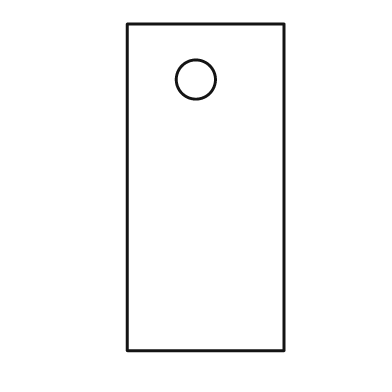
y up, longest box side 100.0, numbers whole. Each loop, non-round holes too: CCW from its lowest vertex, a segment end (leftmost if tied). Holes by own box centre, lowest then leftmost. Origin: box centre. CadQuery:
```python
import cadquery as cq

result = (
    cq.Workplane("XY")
    .moveTo(-24.0, -50.0)
    .lineTo(24.0, -50.0)
    .lineTo(24.0, 50.0)
    .lineTo(-24.0, 50.0)
    .close()
    .moveTo(-3.0, 33.0)
    .circle(6.0)
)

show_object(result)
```